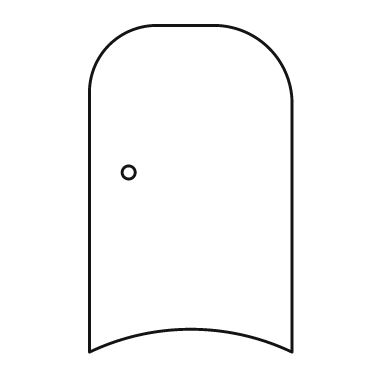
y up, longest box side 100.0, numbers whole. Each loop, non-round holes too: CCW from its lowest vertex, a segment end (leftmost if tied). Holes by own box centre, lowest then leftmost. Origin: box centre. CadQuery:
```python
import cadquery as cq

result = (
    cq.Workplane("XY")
    .moveTo(-31.0, -50.0)
    .threePointArc((0.0, -43.0), (31.0, -50.0))
    .lineTo(31.0, 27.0)
    .threePointArc((24.0, 43.0), (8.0, 50.0))
    .lineTo(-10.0, 50.0)
    .threePointArc((-25.0, 44.0), (-31.0, 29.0))
    .close()
    .moveTo(-19.0, 5.0)
    .circle(2.0)
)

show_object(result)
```